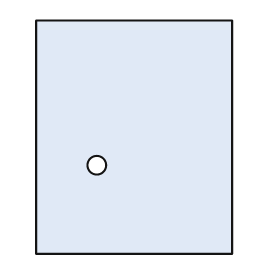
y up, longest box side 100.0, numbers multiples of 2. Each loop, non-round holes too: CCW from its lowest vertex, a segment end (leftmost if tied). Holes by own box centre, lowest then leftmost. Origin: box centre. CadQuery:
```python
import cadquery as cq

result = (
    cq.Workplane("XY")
    .moveTo(-42.0, -50.0)
    .lineTo(42.0, -50.0)
    .lineTo(42.0, 50.0)
    .lineTo(-42.0, 50.0)
    .close()
    .moveTo(-16.0, -12.0)
    .circle(4.0)
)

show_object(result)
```